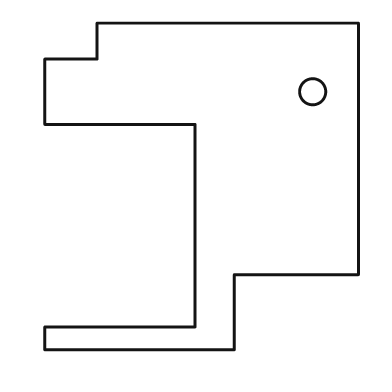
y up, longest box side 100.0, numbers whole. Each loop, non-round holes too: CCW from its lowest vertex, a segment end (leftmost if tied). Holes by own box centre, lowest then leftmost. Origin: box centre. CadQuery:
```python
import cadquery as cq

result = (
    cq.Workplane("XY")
    .moveTo(-48.0, -50.0)
    .lineTo(10.0, -50.0)
    .lineTo(10.0, -27.0)
    .lineTo(48.0, -27.0)
    .lineTo(48.0, 50.0)
    .lineTo(-32.0, 50.0)
    .lineTo(-32.0, 39.0)
    .lineTo(-48.0, 39.0)
    .lineTo(-48.0, 19.0)
    .lineTo(-2.0, 19.0)
    .lineTo(-2.0, -43.0)
    .lineTo(-48.0, -43.0)
    .close()
    .moveTo(34.0, 29.0)
    .circle(4.0)
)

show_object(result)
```